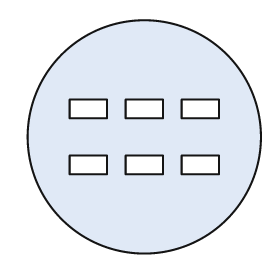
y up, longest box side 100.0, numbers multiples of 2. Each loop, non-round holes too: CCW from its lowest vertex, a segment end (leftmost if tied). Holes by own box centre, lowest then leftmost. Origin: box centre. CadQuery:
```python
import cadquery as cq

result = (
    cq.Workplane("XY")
    .moveTo(0.0, 0.0)
    .circle(50.0)
    .moveTo(-32.0, -16.0)
    .lineTo(-16.0, -16.0)
    .lineTo(-16.0, -8.0)
    .lineTo(-32.0, -8.0)
    .close()
    .moveTo(-8.0, -16.0)
    .lineTo(8.0, -16.0)
    .lineTo(8.0, -8.0)
    .lineTo(-8.0, -8.0)
    .close()
    .moveTo(16.0, -16.0)
    .lineTo(32.0, -16.0)
    .lineTo(32.0, -8.0)
    .lineTo(16.0, -8.0)
    .close()
    .moveTo(-32.0, 8.0)
    .lineTo(-16.0, 8.0)
    .lineTo(-16.0, 16.0)
    .lineTo(-32.0, 16.0)
    .close()
    .moveTo(-8.0, 8.0)
    .lineTo(8.0, 8.0)
    .lineTo(8.0, 16.0)
    .lineTo(-8.0, 16.0)
    .close()
    .moveTo(16.0, 8.0)
    .lineTo(32.0, 8.0)
    .lineTo(32.0, 16.0)
    .lineTo(16.0, 16.0)
    .close()
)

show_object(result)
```